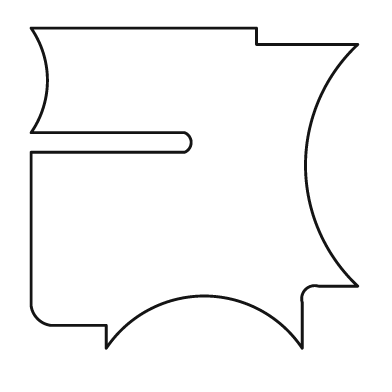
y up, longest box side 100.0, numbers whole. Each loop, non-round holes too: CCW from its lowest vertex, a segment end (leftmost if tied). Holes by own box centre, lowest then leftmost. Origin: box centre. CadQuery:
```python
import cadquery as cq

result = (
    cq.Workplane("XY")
    .moveTo(-27.0, -49.0)
    .threePointArc((3.0, -33.0), (33.0, -49.0))
    .lineTo(33.0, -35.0)
    .threePointArc((34.0, -31.0), (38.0, -30.0))
    .lineTo(50.0, -30.0)
    .threePointArc((34.0, 7.0), (50.0, 44.0))
    .lineTo(19.0, 44.0)
    .lineTo(19.0, 49.0)
    .lineTo(-50.0, 49.0)
    .threePointArc((-45.0, 33.0), (-50.0, 17.0))
    .lineTo(-3.0, 17.0)
    .threePointArc((-1.0, 14.0), (-3.0, 11.0))
    .lineTo(-50.0, 11.0)
    .lineTo(-50.0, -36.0)
    .threePointArc((-48.0, -40.0), (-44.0, -42.0))
    .lineTo(-27.0, -42.0)
    .close()
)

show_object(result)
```